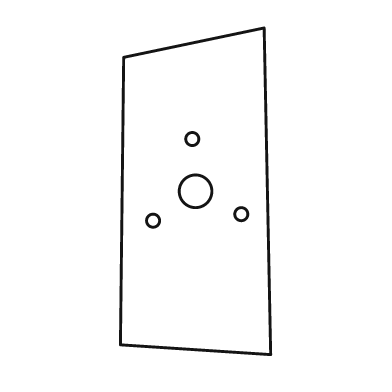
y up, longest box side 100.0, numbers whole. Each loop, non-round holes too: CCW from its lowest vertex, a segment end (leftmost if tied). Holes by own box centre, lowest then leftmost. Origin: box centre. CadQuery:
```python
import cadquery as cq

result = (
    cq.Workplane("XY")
    .moveTo(23.0, -50.0)
    .lineTo(21.0, 50.0)
    .lineTo(-22.0, 41.0)
    .lineTo(-23.0, -47.0)
    .close()
    .moveTo(-13.0, -9.0)
    .circle(2.0)
    .moveTo(14.0, -7.0)
    .circle(2.0)
    .moveTo(0.0, 0.0)
    .circle(5.0)
    .moveTo(-1.0, 16.0)
    .circle(2.0)
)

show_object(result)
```